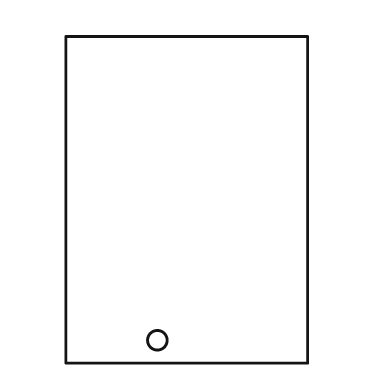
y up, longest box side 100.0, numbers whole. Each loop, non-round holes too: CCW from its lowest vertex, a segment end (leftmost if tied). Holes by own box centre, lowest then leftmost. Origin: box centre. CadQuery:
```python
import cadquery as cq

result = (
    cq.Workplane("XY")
    .moveTo(-37.0, -50.0)
    .lineTo(37.0, -50.0)
    .lineTo(37.0, 50.0)
    .lineTo(-37.0, 50.0)
    .close()
    .moveTo(-9.0, -43.0)
    .circle(3.0)
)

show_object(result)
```